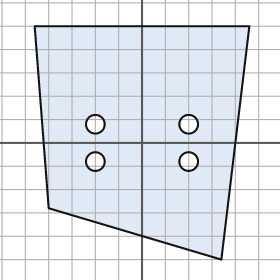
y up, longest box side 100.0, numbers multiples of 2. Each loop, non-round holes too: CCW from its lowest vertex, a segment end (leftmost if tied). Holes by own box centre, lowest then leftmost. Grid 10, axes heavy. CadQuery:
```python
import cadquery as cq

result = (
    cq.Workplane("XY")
    .moveTo(34.0, -50.0)
    .lineTo(46.0, 50.0)
    .lineTo(-46.0, 50.0)
    .lineTo(-40.0, -28.0)
    .close()
    .moveTo(-20.0, -8.0)
    .circle(4.0)
    .moveTo(20.0, -8.0)
    .circle(4.0)
    .moveTo(-20.0, 8.0)
    .circle(4.0)
    .moveTo(20.0, 8.0)
    .circle(4.0)
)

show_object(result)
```